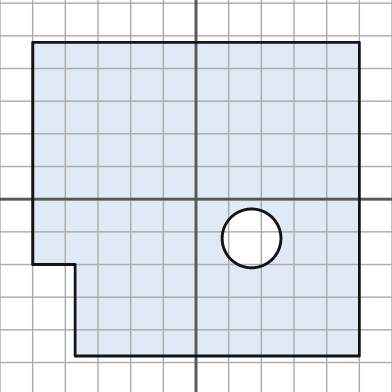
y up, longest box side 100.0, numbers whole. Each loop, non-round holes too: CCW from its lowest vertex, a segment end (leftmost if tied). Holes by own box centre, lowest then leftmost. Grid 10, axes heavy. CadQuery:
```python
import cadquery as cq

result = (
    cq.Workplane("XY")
    .moveTo(-37.0, -48.0)
    .lineTo(50.0, -48.0)
    .lineTo(50.0, 48.0)
    .lineTo(-50.0, 48.0)
    .lineTo(-50.0, -20.0)
    .lineTo(-37.0, -20.0)
    .close()
    .moveTo(17.0, -12.0)
    .circle(9.0)
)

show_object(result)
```